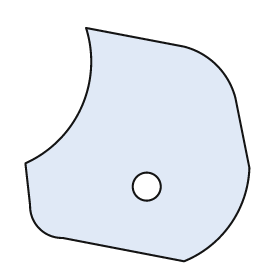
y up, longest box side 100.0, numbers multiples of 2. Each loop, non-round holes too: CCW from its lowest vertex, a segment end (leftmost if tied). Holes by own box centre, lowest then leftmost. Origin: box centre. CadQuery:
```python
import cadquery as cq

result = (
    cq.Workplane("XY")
    .moveTo(20.0, -50.0)
    .threePointArc((40.0, -34.0), (48.0, -10.0))
    .lineTo(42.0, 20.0)
    .threePointArc((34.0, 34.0), (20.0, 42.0))
    .lineTo(-22.0, 50.0)
    .threePointArc((-24.0, 16.0), (-48.0, -8.0))
    .lineTo(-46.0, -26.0)
    .threePointArc((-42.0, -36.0), (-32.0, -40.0))
    .close()
    .moveTo(4.0, -18.0)
    .circle(6.0)
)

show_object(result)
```